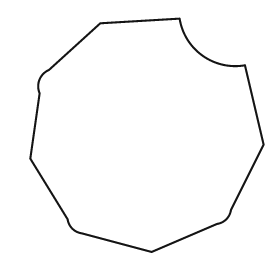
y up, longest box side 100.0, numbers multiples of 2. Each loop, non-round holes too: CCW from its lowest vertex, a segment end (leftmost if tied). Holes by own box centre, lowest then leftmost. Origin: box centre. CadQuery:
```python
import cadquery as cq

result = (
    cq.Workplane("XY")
    .moveTo(2.0, -50.0)
    .lineTo(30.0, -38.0)
    .threePointArc((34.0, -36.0), (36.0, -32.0))
    .lineTo(50.0, -4.0)
    .lineTo(42.0, 30.0)
    .threePointArc((24.0, 34.0), (14.0, 50.0))
    .lineTo(-20.0, 48.0)
    .lineTo(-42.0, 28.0)
    .threePointArc((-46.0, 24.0), (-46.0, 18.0))
    .lineTo(-50.0, -10.0)
    .lineTo(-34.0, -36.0)
    .threePointArc((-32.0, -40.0), (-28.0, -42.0))
    .close()
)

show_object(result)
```